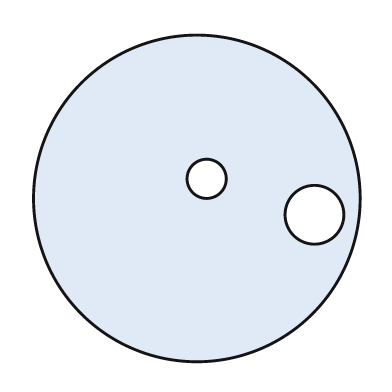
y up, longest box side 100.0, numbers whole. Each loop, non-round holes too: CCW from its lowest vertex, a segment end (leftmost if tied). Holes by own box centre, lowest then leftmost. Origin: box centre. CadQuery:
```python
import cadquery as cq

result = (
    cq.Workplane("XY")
    .moveTo(0.0, 0.0)
    .circle(50.0)
    .moveTo(36.0, -5.0)
    .circle(9.0)
    .moveTo(3.0, 6.0)
    .circle(6.0)
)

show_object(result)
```